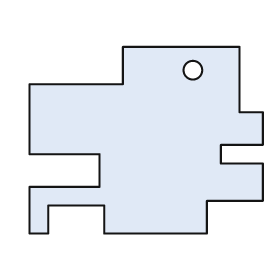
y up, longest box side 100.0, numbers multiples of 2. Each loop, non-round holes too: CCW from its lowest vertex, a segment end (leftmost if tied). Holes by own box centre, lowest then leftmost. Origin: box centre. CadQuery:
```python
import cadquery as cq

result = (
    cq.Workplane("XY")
    .moveTo(-50.0, -40.0)
    .lineTo(-42.0, -40.0)
    .lineTo(-42.0, -28.0)
    .lineTo(-18.0, -28.0)
    .lineTo(-18.0, -40.0)
    .lineTo(26.0, -40.0)
    .lineTo(26.0, -26.0)
    .lineTo(50.0, -26.0)
    .lineTo(50.0, -10.0)
    .lineTo(32.0, -10.0)
    .lineTo(32.0, -2.0)
    .lineTo(50.0, -2.0)
    .lineTo(50.0, 12.0)
    .lineTo(40.0, 12.0)
    .lineTo(40.0, 40.0)
    .lineTo(-10.0, 40.0)
    .lineTo(-10.0, 24.0)
    .lineTo(-50.0, 24.0)
    .lineTo(-50.0, -6.0)
    .lineTo(-20.0, -6.0)
    .lineTo(-20.0, -20.0)
    .lineTo(-50.0, -20.0)
    .close()
    .moveTo(20.0, 30.0)
    .circle(4.0)
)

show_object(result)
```